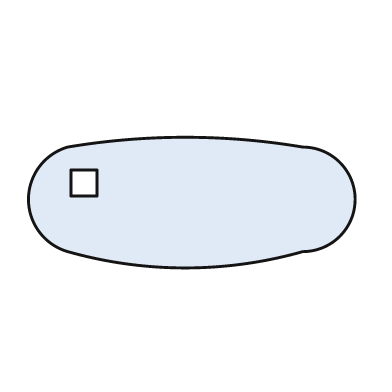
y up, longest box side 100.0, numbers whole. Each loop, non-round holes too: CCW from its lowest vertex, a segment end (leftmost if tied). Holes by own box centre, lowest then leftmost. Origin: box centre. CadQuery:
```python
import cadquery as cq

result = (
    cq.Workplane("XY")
    .moveTo(-38.0, -15.0)
    .threePointArc((-2.0, -20.0), (34.0, -15.0))
    .threePointArc((50.0, 1.0), (34.0, 17.0))
    .threePointArc((-2.0, 20.0), (-38.0, 17.0))
    .threePointArc((-50.0, 1.0), (-38.0, -15.0))
    .close()
    .moveTo(-37.0, 2.0)
    .lineTo(-29.0, 2.0)
    .lineTo(-29.0, 10.0)
    .lineTo(-37.0, 10.0)
    .close()
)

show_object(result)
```